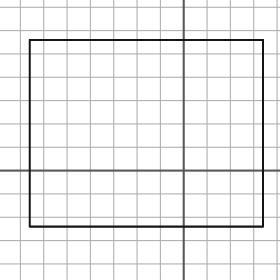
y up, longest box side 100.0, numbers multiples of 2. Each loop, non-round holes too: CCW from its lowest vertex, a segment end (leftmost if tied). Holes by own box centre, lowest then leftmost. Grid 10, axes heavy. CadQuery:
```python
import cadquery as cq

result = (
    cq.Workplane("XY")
    .moveTo(-66.0, -24.0)
    .lineTo(34.0, -24.0)
    .lineTo(34.0, 56.0)
    .lineTo(-66.0, 56.0)
    .close()
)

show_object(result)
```